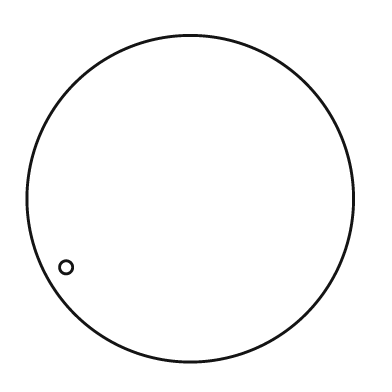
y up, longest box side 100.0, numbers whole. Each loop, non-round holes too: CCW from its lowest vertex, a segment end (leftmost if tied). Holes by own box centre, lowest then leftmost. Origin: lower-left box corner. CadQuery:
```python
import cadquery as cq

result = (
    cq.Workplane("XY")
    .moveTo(50.0, 50.0)
    .circle(50.0)
    .moveTo(12.0, 29.0)
    .circle(2.0)
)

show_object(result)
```